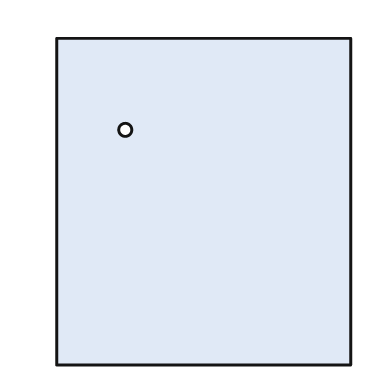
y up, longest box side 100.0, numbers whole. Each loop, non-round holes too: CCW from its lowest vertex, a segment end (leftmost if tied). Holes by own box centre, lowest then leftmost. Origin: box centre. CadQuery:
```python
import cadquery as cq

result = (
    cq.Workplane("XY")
    .moveTo(-45.0, -50.0)
    .lineTo(45.0, -50.0)
    .lineTo(45.0, 50.0)
    .lineTo(-45.0, 50.0)
    .close()
    .moveTo(-24.0, 22.0)
    .circle(2.0)
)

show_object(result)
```